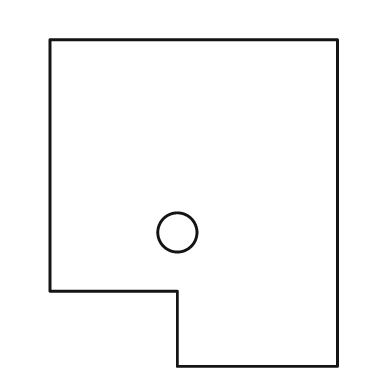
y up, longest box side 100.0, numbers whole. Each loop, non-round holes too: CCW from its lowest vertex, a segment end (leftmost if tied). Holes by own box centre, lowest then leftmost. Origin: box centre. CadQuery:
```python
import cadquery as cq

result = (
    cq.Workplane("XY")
    .moveTo(-5.0, -50.0)
    .lineTo(44.0, -50.0)
    .lineTo(44.0, 50.0)
    .lineTo(-44.0, 50.0)
    .lineTo(-44.0, -27.0)
    .lineTo(-5.0, -27.0)
    .close()
    .moveTo(-5.0, -9.0)
    .circle(6.0)
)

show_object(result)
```